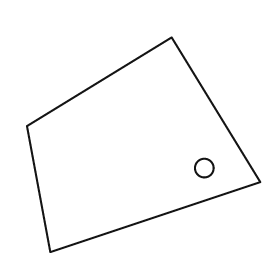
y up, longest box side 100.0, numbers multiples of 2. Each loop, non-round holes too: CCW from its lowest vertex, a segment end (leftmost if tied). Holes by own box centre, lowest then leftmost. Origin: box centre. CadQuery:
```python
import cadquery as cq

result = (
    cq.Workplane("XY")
    .moveTo(-40.0, -46.0)
    .lineTo(50.0, -16.0)
    .lineTo(12.0, 46.0)
    .lineTo(-50.0, 8.0)
    .close()
    .moveTo(26.0, -10.0)
    .circle(4.0)
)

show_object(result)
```